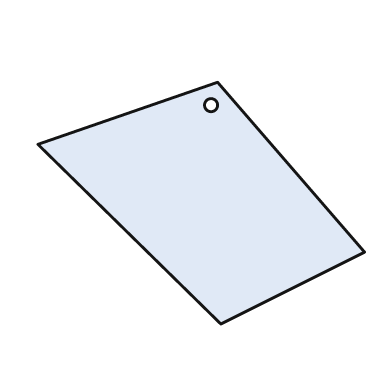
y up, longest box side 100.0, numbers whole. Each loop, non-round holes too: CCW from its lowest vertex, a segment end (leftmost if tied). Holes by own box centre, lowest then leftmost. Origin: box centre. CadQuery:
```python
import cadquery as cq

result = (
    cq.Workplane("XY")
    .moveTo(6.0, -37.0)
    .lineTo(50.0, -15.0)
    .lineTo(5.0, 37.0)
    .lineTo(-50.0, 18.0)
    .close()
    .moveTo(3.0, 30.0)
    .circle(2.0)
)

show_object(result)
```